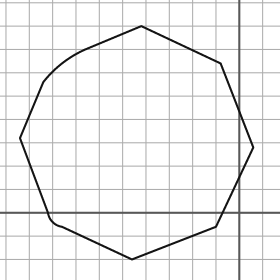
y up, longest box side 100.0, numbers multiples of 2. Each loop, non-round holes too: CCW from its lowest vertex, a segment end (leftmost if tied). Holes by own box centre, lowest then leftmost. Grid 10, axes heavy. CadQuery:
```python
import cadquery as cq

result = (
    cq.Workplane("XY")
    .moveTo(-46.0, -20.0)
    .lineTo(-10.0, -6.0)
    .lineTo(6.0, 28.0)
    .lineTo(-8.0, 64.0)
    .lineTo(-42.0, 80.0)
    .lineTo(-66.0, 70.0)
    .threePointArc((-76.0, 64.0), (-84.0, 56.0))
    .lineTo(-94.0, 32.0)
    .lineTo(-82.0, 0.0)
    .threePointArc((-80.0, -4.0), (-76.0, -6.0))
    .close()
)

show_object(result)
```